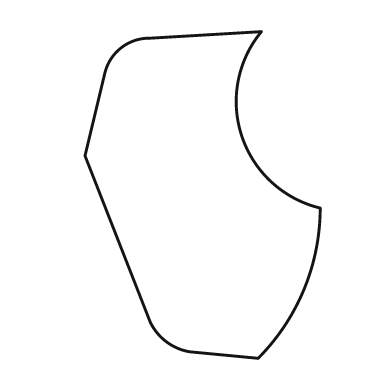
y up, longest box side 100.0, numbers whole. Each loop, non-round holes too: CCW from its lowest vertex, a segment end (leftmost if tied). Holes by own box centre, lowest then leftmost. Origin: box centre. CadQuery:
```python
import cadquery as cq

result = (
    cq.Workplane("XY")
    .moveTo(17.0, -50.0)
    .threePointArc((31.0, -29.0), (36.0, -4.0))
    .threePointArc((12.0, 18.0), (18.0, 50.0))
    .lineTo(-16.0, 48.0)
    .threePointArc((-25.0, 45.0), (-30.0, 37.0))
    .lineTo(-36.0, 12.0)
    .lineTo(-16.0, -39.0)
    .threePointArc((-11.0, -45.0), (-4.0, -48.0))
    .close()
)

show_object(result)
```